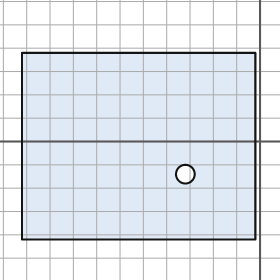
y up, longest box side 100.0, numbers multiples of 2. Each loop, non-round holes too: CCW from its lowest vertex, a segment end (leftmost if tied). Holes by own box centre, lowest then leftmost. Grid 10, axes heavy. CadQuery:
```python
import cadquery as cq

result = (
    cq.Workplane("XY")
    .moveTo(-102.0, -42.0)
    .lineTo(-2.0, -42.0)
    .lineTo(-2.0, 38.0)
    .lineTo(-102.0, 38.0)
    .close()
    .moveTo(-32.0, -14.0)
    .circle(4.0)
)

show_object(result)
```